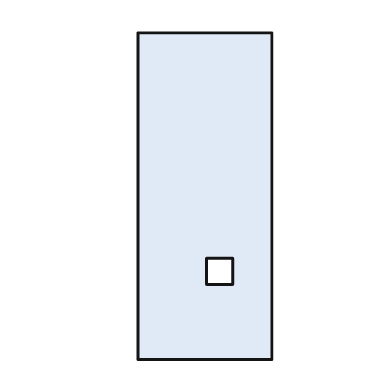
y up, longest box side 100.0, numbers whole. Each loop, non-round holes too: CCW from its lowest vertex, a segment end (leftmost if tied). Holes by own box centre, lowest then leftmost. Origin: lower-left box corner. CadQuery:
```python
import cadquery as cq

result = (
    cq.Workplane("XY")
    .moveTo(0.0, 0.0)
    .lineTo(41.0, 0.0)
    .lineTo(41.0, 100.0)
    .lineTo(0.0, 100.0)
    .close()
    .moveTo(21.0, 23.0)
    .lineTo(29.0, 23.0)
    .lineTo(29.0, 31.0)
    .lineTo(21.0, 31.0)
    .close()
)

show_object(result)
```